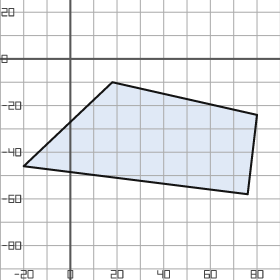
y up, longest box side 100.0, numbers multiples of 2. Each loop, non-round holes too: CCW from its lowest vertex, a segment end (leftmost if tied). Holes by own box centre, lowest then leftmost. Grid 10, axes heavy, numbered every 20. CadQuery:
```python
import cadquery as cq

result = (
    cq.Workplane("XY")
    .moveTo(76.0, -58.0)
    .lineTo(80.0, -24.0)
    .lineTo(18.0, -10.0)
    .lineTo(-20.0, -46.0)
    .close()
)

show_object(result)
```